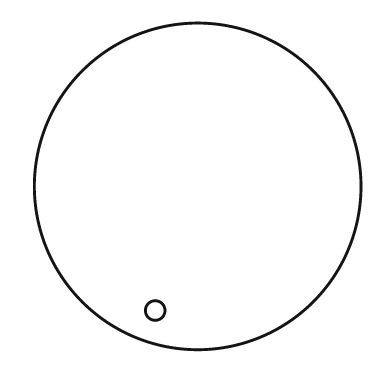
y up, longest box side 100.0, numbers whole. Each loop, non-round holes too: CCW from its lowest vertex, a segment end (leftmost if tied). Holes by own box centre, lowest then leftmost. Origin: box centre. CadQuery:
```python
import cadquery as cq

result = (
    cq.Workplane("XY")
    .moveTo(0.0, 0.0)
    .circle(50.0)
    .moveTo(-13.0, -38.0)
    .circle(3.0)
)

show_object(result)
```